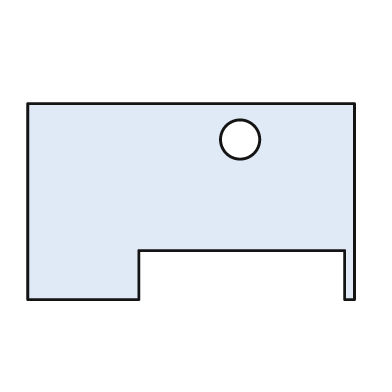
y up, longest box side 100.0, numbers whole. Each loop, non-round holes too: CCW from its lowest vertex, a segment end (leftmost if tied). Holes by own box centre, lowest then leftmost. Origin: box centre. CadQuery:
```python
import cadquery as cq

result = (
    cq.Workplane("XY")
    .moveTo(-50.0, -30.0)
    .lineTo(-16.0, -30.0)
    .lineTo(-16.0, -15.0)
    .lineTo(47.0, -15.0)
    .lineTo(47.0, -30.0)
    .lineTo(50.0, -30.0)
    .lineTo(50.0, 30.0)
    .lineTo(-50.0, 30.0)
    .close()
    .moveTo(15.0, 19.0)
    .circle(6.0)
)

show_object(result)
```